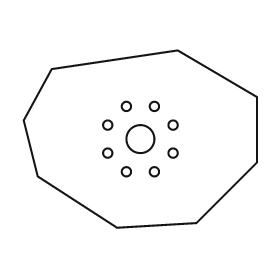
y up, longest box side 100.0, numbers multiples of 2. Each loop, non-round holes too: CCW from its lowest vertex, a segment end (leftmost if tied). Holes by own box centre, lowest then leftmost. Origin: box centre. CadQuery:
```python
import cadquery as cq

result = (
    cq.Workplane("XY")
    .moveTo(-10.0, -38.0)
    .lineTo(24.0, -36.0)
    .lineTo(50.0, -10.0)
    .lineTo(50.0, 18.0)
    .lineTo(16.0, 38.0)
    .lineTo(-38.0, 30.0)
    .lineTo(-50.0, 8.0)
    .lineTo(-44.0, -16.0)
    .close()
    .moveTo(-6.0, -14.0)
    .circle(2.0)
    .moveTo(6.0, -14.0)
    .circle(2.0)
    .moveTo(-14.0, -6.0)
    .circle(2.0)
    .moveTo(14.0, -6.0)
    .circle(2.0)
    .moveTo(0.0, 0.0)
    .circle(6.0)
    .moveTo(-14.0, 6.0)
    .circle(2.0)
    .moveTo(14.0, 6.0)
    .circle(2.0)
    .moveTo(-6.0, 14.0)
    .circle(2.0)
    .moveTo(6.0, 14.0)
    .circle(2.0)
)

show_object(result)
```